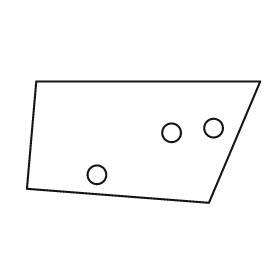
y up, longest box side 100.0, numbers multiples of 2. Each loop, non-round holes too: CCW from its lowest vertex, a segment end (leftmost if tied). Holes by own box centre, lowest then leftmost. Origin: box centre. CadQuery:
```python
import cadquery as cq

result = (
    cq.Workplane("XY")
    .moveTo(28.0, -26.0)
    .lineTo(50.0, 26.0)
    .lineTo(-46.0, 26.0)
    .lineTo(-50.0, -20.0)
    .close()
    .moveTo(-20.0, -14.0)
    .circle(4.0)
    .moveTo(12.0, 4.0)
    .circle(4.0)
    .moveTo(30.0, 6.0)
    .circle(4.0)
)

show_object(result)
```